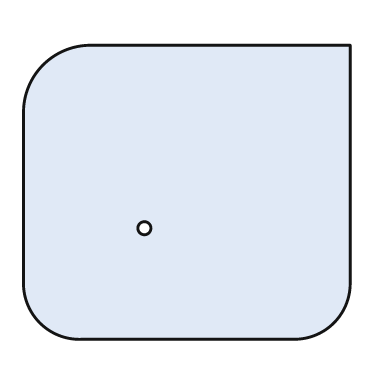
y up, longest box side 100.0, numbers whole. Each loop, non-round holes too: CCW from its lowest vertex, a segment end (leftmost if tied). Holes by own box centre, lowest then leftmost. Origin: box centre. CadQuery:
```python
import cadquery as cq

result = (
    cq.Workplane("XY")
    .moveTo(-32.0, -45.0)
    .lineTo(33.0, -45.0)
    .threePointArc((45.0, -40.0), (50.0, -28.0))
    .lineTo(50.0, 45.0)
    .lineTo(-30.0, 45.0)
    .threePointArc((-44.0, 39.0), (-50.0, 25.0))
    .lineTo(-50.0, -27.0)
    .threePointArc((-45.0, -40.0), (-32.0, -45.0))
    .close()
    .moveTo(-13.0, -11.0)
    .circle(2.0)
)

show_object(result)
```